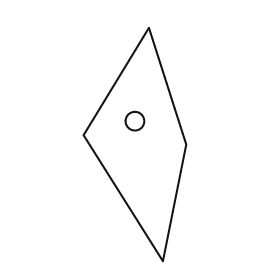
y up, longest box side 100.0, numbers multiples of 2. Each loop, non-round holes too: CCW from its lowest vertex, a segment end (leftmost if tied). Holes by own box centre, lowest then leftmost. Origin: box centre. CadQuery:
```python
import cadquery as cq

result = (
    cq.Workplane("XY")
    .moveTo(12.0, -50.0)
    .lineTo(22.0, 0.0)
    .lineTo(6.0, 50.0)
    .lineTo(-22.0, 4.0)
    .close()
    .moveTo(0.0, 10.0)
    .circle(4.0)
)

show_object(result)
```